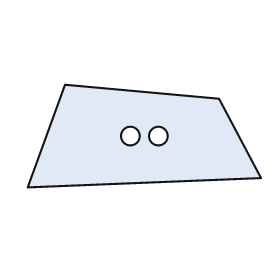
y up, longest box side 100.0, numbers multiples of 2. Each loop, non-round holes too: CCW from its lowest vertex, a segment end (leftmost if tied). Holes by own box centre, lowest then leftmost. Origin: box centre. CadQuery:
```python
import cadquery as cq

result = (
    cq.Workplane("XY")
    .moveTo(-50.0, -22.0)
    .lineTo(50.0, -18.0)
    .lineTo(32.0, 16.0)
    .lineTo(-34.0, 22.0)
    .close()
    .moveTo(-6.0, 0.0)
    .circle(4.0)
    .moveTo(6.0, 0.0)
    .circle(4.0)
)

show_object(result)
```